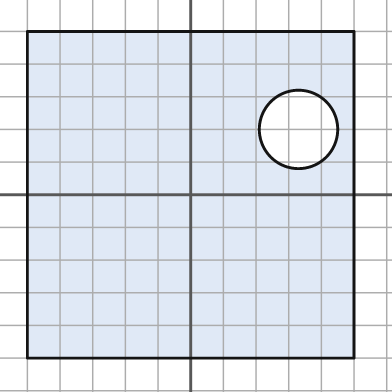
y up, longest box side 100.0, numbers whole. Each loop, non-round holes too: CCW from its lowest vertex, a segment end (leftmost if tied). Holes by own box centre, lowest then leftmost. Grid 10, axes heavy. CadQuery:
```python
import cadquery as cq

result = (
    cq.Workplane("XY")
    .moveTo(-50.0, -50.0)
    .lineTo(50.0, -50.0)
    .lineTo(50.0, 50.0)
    .lineTo(-50.0, 50.0)
    .close()
    .moveTo(33.0, 20.0)
    .circle(12.0)
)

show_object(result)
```